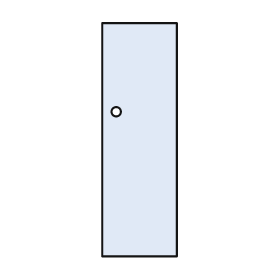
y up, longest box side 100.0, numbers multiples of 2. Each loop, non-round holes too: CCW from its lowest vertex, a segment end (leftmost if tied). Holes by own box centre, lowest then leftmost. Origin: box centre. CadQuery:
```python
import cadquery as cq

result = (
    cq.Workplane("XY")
    .moveTo(-16.0, -50.0)
    .lineTo(16.0, -50.0)
    .lineTo(16.0, 50.0)
    .lineTo(-16.0, 50.0)
    .close()
    .moveTo(-10.0, 12.0)
    .circle(2.0)
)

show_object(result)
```